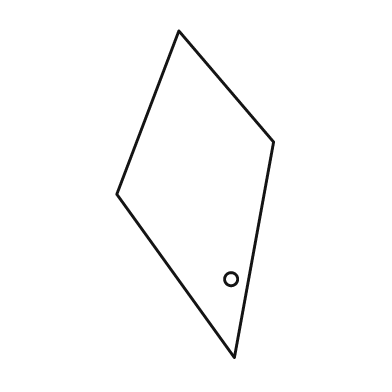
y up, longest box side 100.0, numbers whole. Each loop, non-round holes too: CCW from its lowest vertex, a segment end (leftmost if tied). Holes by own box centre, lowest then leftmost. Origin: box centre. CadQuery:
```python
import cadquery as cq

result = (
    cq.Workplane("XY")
    .moveTo(12.0, -50.0)
    .lineTo(24.0, 16.0)
    .lineTo(-5.0, 50.0)
    .lineTo(-24.0, 0.0)
    .close()
    .moveTo(11.0, -26.0)
    .circle(2.0)
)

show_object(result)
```